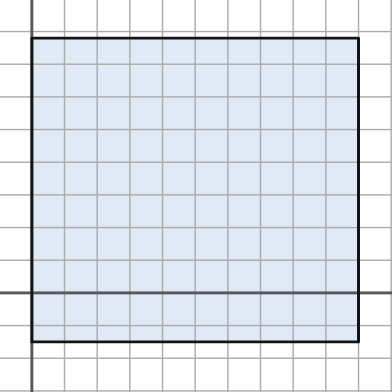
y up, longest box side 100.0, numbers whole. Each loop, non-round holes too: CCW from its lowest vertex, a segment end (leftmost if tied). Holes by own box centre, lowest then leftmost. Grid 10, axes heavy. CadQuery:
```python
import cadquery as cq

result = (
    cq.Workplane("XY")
    .moveTo(0.0, -15.0)
    .lineTo(100.0, -15.0)
    .lineTo(100.0, 78.0)
    .lineTo(0.0, 78.0)
    .close()
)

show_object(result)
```